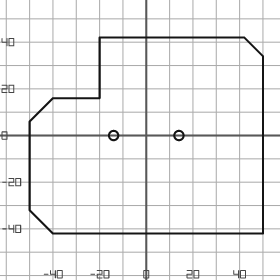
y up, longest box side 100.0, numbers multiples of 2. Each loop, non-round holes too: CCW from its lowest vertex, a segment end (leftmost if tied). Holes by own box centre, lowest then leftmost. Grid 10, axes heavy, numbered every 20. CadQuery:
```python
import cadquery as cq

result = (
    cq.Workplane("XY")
    .moveTo(-40.0, -42.0)
    .lineTo(50.0, -42.0)
    .lineTo(50.0, 34.0)
    .lineTo(42.0, 42.0)
    .lineTo(-20.0, 42.0)
    .lineTo(-20.0, 16.0)
    .lineTo(-40.0, 16.0)
    .lineTo(-50.0, 6.0)
    .lineTo(-50.0, -32.0)
    .close()
    .moveTo(-14.0, 0.0)
    .circle(2.0)
    .moveTo(14.0, 0.0)
    .circle(2.0)
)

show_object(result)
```